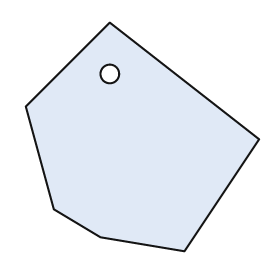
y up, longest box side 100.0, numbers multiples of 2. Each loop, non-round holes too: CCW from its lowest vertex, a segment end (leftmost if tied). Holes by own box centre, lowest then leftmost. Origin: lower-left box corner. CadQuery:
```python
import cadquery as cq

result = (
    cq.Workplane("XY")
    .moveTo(68.0, 0.0)
    .lineTo(100.0, 48.0)
    .lineTo(36.0, 98.0)
    .lineTo(0.0, 62.0)
    .lineTo(12.0, 18.0)
    .lineTo(32.0, 6.0)
    .close()
    .moveTo(36.0, 76.0)
    .circle(4.0)
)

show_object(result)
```